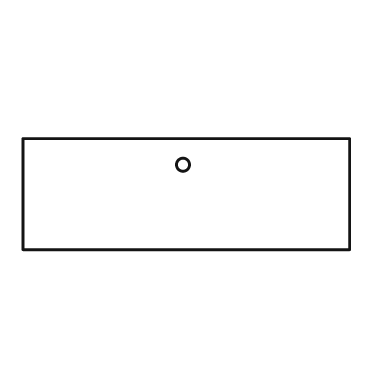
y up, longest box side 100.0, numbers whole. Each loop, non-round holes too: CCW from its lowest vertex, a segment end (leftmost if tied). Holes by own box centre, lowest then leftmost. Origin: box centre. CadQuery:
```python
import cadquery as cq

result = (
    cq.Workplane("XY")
    .moveTo(-50.0, -17.0)
    .lineTo(50.0, -17.0)
    .lineTo(50.0, 17.0)
    .lineTo(-50.0, 17.0)
    .close()
    .moveTo(-1.0, 9.0)
    .circle(2.0)
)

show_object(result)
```